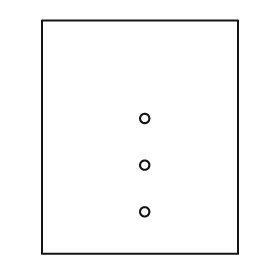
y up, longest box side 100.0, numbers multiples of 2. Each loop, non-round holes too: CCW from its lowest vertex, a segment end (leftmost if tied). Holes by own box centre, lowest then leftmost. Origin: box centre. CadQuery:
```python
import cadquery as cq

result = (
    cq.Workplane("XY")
    .moveTo(-42.0, -50.0)
    .lineTo(42.0, -50.0)
    .lineTo(42.0, 50.0)
    .lineTo(-42.0, 50.0)
    .close()
    .moveTo(2.0, -32.0)
    .circle(2.0)
    .moveTo(2.0, -12.0)
    .circle(2.0)
    .moveTo(2.0, 8.0)
    .circle(2.0)
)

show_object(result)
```